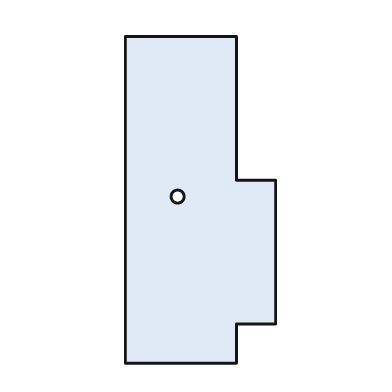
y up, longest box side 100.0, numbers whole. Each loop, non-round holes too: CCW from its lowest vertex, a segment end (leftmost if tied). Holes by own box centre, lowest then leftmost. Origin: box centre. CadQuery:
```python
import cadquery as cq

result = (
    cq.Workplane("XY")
    .moveTo(-23.0, -50.0)
    .lineTo(11.0, -50.0)
    .lineTo(11.0, -38.0)
    .lineTo(23.0, -38.0)
    .lineTo(23.0, 6.0)
    .lineTo(11.0, 6.0)
    .lineTo(11.0, 50.0)
    .lineTo(-23.0, 50.0)
    .close()
    .moveTo(-7.0, 1.0)
    .circle(2.0)
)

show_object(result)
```